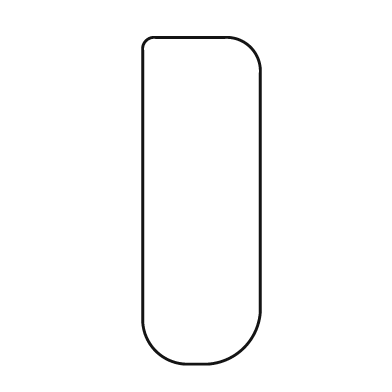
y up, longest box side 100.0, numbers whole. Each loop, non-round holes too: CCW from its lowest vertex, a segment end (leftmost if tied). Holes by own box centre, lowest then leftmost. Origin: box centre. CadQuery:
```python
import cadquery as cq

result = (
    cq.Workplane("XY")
    .moveTo(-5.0, -50.0)
    .lineTo(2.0, -50.0)
    .threePointArc((13.0, -45.0), (18.0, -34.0))
    .lineTo(18.0, 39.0)
    .threePointArc((15.0, 47.0), (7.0, 50.0))
    .lineTo(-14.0, 50.0)
    .threePointArc((-17.0, 49.0), (-18.0, 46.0))
    .lineTo(-18.0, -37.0)
    .threePointArc((-14.0, -46.0), (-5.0, -50.0))
    .close()
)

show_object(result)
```